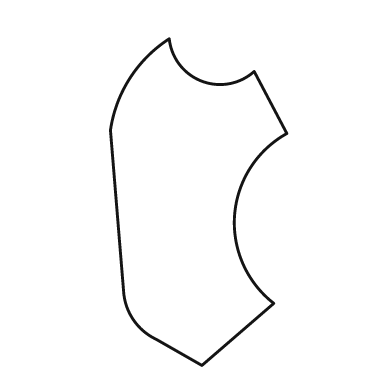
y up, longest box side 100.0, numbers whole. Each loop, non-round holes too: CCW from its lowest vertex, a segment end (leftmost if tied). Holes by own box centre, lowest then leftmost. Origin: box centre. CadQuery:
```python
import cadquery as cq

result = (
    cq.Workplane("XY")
    .moveTo(1.0, -50.0)
    .lineTo(23.0, -31.0)
    .threePointArc((11.0, -4.0), (27.0, 21.0))
    .lineTo(17.0, 40.0)
    .threePointArc((1.0, 37.0), (-9.0, 50.0))
    .threePointArc((-21.0, 38.0), (-27.0, 22.0))
    .lineTo(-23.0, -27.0)
    .threePointArc((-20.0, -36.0), (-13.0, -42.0))
    .close()
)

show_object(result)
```